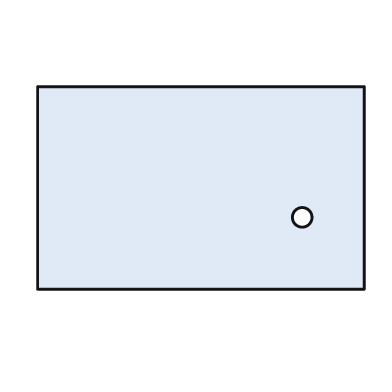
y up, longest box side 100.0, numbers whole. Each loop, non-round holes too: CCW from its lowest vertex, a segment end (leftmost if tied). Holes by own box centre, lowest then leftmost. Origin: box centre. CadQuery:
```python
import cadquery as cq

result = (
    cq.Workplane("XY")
    .moveTo(-50.0, -31.0)
    .lineTo(50.0, -31.0)
    .lineTo(50.0, 31.0)
    .lineTo(-50.0, 31.0)
    .close()
    .moveTo(31.0, -9.0)
    .circle(3.0)
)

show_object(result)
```